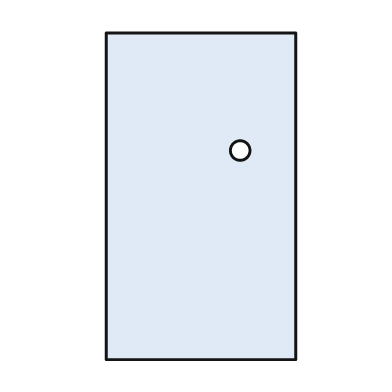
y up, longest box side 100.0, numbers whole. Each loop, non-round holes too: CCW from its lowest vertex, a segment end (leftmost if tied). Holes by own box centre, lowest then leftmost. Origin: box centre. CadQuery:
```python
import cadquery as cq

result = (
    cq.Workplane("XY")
    .moveTo(-29.0, -50.0)
    .lineTo(29.0, -50.0)
    .lineTo(29.0, 50.0)
    .lineTo(-29.0, 50.0)
    .close()
    .moveTo(12.0, 14.0)
    .circle(3.0)
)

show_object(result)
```